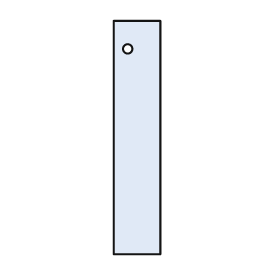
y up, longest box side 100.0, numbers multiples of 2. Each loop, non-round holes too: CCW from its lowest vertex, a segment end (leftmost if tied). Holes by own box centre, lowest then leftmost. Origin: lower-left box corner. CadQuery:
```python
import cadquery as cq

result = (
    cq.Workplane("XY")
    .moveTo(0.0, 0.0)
    .lineTo(20.0, 0.0)
    .lineTo(20.0, 100.0)
    .lineTo(0.0, 100.0)
    .close()
    .moveTo(6.0, 88.0)
    .circle(2.0)
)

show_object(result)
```